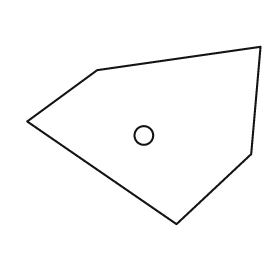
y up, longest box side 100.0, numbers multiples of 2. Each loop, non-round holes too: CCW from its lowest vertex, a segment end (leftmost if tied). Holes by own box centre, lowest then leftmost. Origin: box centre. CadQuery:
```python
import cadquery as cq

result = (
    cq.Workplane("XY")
    .moveTo(14.0, -38.0)
    .lineTo(46.0, -8.0)
    .lineTo(50.0, 38.0)
    .lineTo(-20.0, 28.0)
    .lineTo(-50.0, 6.0)
    .close()
    .moveTo(0.0, 0.0)
    .circle(4.0)
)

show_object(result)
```